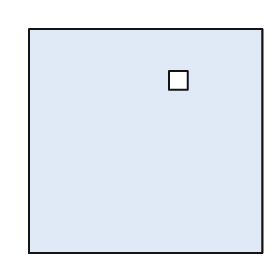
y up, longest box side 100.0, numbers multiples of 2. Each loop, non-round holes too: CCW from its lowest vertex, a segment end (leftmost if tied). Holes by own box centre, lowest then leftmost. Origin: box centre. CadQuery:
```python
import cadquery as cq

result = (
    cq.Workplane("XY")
    .moveTo(-50.0, -48.0)
    .lineTo(50.0, -48.0)
    .lineTo(50.0, 48.0)
    .lineTo(-50.0, 48.0)
    .close()
    .moveTo(10.0, 22.0)
    .lineTo(18.0, 22.0)
    .lineTo(18.0, 30.0)
    .lineTo(10.0, 30.0)
    .close()
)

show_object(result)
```